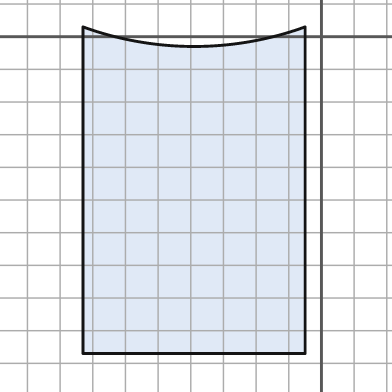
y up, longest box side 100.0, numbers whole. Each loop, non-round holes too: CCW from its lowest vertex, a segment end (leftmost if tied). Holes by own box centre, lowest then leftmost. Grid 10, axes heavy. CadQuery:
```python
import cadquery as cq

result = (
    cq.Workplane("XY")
    .moveTo(-73.0, -97.0)
    .lineTo(-5.0, -97.0)
    .lineTo(-5.0, 3.0)
    .threePointArc((-39.0, -3.0), (-73.0, 3.0))
    .close()
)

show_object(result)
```